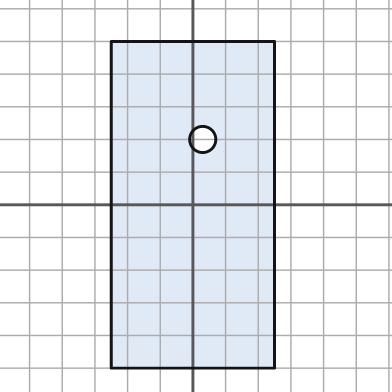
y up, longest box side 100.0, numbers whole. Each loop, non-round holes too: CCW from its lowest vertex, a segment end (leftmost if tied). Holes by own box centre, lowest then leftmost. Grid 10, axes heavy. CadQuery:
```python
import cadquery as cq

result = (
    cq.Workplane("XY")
    .moveTo(-25.0, -50.0)
    .lineTo(25.0, -50.0)
    .lineTo(25.0, 50.0)
    .lineTo(-25.0, 50.0)
    .close()
    .moveTo(3.0, 20.0)
    .circle(4.0)
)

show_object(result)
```